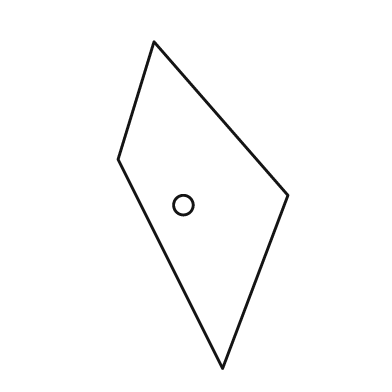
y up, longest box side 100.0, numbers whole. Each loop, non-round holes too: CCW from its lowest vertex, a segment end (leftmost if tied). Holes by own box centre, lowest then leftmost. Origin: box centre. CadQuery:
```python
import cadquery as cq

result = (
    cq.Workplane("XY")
    .moveTo(6.0, -50.0)
    .lineTo(26.0, 3.0)
    .lineTo(-15.0, 50.0)
    .lineTo(-26.0, 14.0)
    .close()
    .moveTo(-6.0, 0.0)
    .circle(3.0)
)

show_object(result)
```